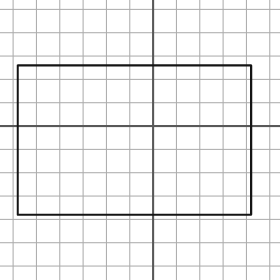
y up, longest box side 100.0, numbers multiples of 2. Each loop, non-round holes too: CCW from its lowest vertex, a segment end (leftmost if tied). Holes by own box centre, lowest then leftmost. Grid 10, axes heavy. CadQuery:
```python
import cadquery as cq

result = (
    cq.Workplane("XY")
    .moveTo(-58.0, -38.0)
    .lineTo(42.0, -38.0)
    .lineTo(42.0, 26.0)
    .lineTo(-58.0, 26.0)
    .close()
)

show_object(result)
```